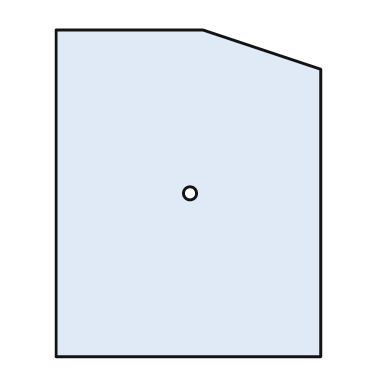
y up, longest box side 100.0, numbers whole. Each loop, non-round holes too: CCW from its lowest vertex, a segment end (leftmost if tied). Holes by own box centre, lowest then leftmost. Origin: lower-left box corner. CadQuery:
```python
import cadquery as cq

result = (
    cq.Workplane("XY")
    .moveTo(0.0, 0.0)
    .lineTo(81.0, 0.0)
    .lineTo(81.0, 88.0)
    .lineTo(45.0, 100.0)
    .lineTo(0.0, 100.0)
    .close()
    .moveTo(41.0, 50.0)
    .circle(2.0)
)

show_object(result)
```